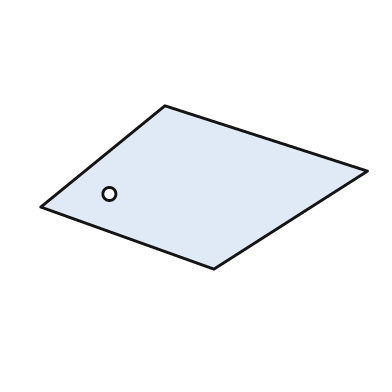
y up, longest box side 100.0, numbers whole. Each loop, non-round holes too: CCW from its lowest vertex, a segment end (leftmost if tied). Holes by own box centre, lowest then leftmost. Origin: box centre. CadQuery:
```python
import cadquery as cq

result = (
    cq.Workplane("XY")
    .moveTo(3.0, -25.0)
    .lineTo(50.0, 5.0)
    .lineTo(-12.0, 25.0)
    .lineTo(-50.0, -6.0)
    .close()
    .moveTo(-29.0, -2.0)
    .circle(2.0)
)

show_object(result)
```